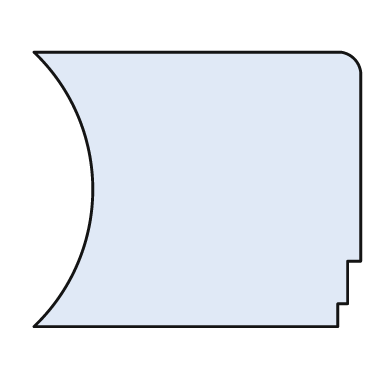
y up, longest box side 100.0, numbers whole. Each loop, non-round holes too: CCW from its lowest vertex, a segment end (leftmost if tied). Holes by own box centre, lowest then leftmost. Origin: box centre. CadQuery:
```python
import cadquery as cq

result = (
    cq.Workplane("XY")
    .moveTo(-50.0, -42.0)
    .lineTo(43.0, -42.0)
    .lineTo(43.0, -35.0)
    .lineTo(46.0, -35.0)
    .lineTo(46.0, -22.0)
    .lineTo(50.0, -22.0)
    .lineTo(50.0, 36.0)
    .threePointArc((48.0, 40.0), (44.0, 42.0))
    .lineTo(-50.0, 42.0)
    .threePointArc((-32.0, 0.0), (-50.0, -42.0))
    .close()
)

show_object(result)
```